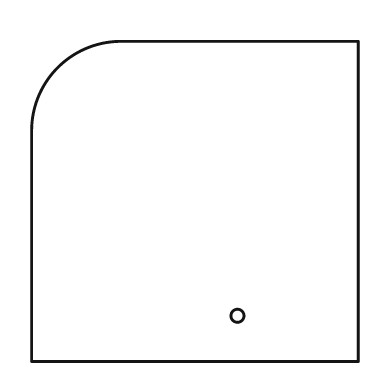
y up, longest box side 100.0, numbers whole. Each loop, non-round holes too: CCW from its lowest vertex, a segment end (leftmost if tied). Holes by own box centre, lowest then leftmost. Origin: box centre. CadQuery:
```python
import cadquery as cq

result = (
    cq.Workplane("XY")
    .moveTo(-50.0, -49.0)
    .lineTo(50.0, -49.0)
    .lineTo(50.0, 49.0)
    .lineTo(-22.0, 49.0)
    .threePointArc((-42.0, 41.0), (-50.0, 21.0))
    .close()
    .moveTo(13.0, -35.0)
    .circle(2.0)
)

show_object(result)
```